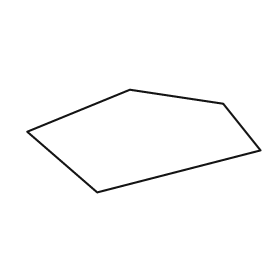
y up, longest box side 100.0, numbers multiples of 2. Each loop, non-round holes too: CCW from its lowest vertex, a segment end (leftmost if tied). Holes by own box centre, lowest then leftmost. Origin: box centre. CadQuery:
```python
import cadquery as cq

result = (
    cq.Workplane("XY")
    .moveTo(-20.0, -22.0)
    .lineTo(50.0, -4.0)
    .lineTo(34.0, 16.0)
    .lineTo(-6.0, 22.0)
    .lineTo(-50.0, 4.0)
    .close()
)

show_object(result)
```